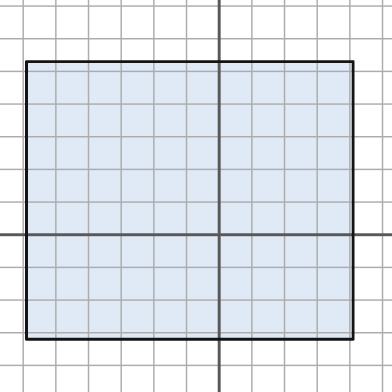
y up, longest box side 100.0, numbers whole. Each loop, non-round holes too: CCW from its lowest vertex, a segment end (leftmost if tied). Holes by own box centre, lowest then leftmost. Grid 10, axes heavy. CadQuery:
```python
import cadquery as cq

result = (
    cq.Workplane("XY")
    .moveTo(-59.0, -32.0)
    .lineTo(41.0, -32.0)
    .lineTo(41.0, 53.0)
    .lineTo(-59.0, 53.0)
    .close()
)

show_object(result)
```